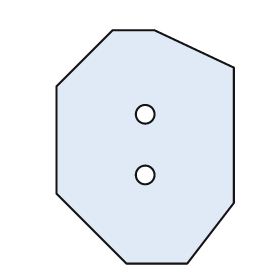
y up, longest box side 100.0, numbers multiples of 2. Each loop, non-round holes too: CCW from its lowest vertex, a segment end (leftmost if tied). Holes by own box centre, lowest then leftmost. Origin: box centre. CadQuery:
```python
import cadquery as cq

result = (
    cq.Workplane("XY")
    .moveTo(-8.0, -50.0)
    .lineTo(18.0, -50.0)
    .lineTo(38.0, -24.0)
    .lineTo(38.0, 34.0)
    .lineTo(4.0, 50.0)
    .lineTo(-14.0, 50.0)
    .lineTo(-38.0, 26.0)
    .lineTo(-38.0, -20.0)
    .close()
    .moveTo(0.0, -12.0)
    .circle(4.0)
    .moveTo(0.0, 14.0)
    .circle(4.0)
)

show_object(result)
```